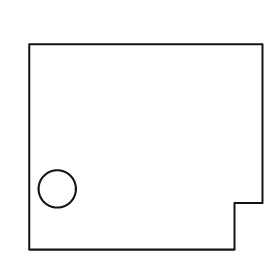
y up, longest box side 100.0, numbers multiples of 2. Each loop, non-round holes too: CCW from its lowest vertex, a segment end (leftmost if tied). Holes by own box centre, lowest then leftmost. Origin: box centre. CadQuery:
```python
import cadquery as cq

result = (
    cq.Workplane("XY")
    .moveTo(-50.0, -44.0)
    .lineTo(38.0, -44.0)
    .lineTo(38.0, -24.0)
    .lineTo(50.0, -24.0)
    .lineTo(50.0, 44.0)
    .lineTo(-50.0, 44.0)
    .close()
    .moveTo(-38.0, -18.0)
    .circle(8.0)
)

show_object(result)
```